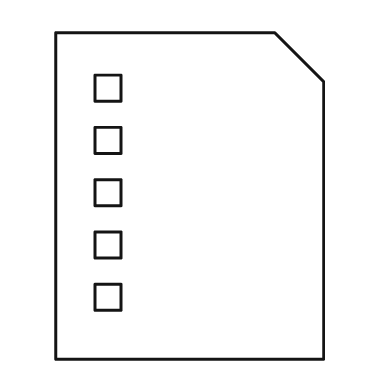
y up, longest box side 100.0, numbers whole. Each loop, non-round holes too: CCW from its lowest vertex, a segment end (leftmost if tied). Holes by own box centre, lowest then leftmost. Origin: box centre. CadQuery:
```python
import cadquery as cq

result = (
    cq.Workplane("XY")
    .moveTo(-41.0, -50.0)
    .lineTo(41.0, -50.0)
    .lineTo(41.0, 35.0)
    .lineTo(26.0, 50.0)
    .lineTo(-41.0, 50.0)
    .close()
    .moveTo(-29.0, -35.0)
    .lineTo(-21.0, -35.0)
    .lineTo(-21.0, -27.0)
    .lineTo(-29.0, -27.0)
    .close()
    .moveTo(-29.0, -19.0)
    .lineTo(-21.0, -19.0)
    .lineTo(-21.0, -11.0)
    .lineTo(-29.0, -11.0)
    .close()
    .moveTo(-29.0, -3.0)
    .lineTo(-21.0, -3.0)
    .lineTo(-21.0, 5.0)
    .lineTo(-29.0, 5.0)
    .close()
    .moveTo(-29.0, 13.0)
    .lineTo(-21.0, 13.0)
    .lineTo(-21.0, 21.0)
    .lineTo(-29.0, 21.0)
    .close()
    .moveTo(-29.0, 29.0)
    .lineTo(-21.0, 29.0)
    .lineTo(-21.0, 37.0)
    .lineTo(-29.0, 37.0)
    .close()
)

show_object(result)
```